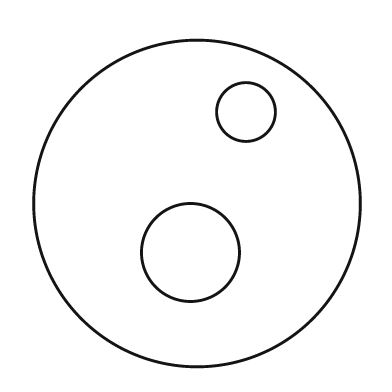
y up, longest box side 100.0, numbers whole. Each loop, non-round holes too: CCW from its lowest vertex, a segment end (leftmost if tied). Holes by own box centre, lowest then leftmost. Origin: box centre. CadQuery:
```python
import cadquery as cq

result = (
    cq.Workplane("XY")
    .moveTo(0.0, 0.0)
    .circle(50.0)
    .moveTo(-2.0, -15.0)
    .circle(15.0)
    .moveTo(15.0, 28.0)
    .circle(9.0)
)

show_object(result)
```